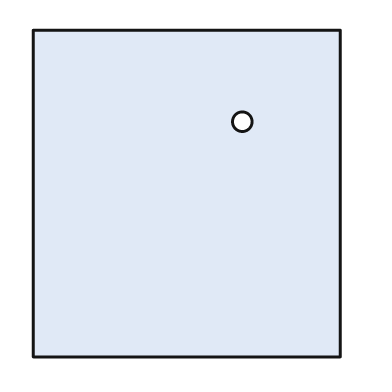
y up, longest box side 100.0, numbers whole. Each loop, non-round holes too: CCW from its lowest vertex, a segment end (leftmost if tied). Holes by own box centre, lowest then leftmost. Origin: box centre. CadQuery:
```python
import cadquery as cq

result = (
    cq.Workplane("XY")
    .moveTo(-47.0, -50.0)
    .lineTo(47.0, -50.0)
    .lineTo(47.0, 50.0)
    .lineTo(-47.0, 50.0)
    .close()
    .moveTo(17.0, 22.0)
    .circle(3.0)
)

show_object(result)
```